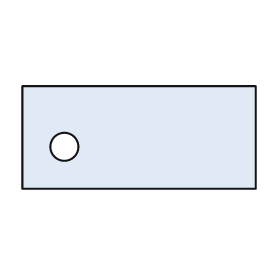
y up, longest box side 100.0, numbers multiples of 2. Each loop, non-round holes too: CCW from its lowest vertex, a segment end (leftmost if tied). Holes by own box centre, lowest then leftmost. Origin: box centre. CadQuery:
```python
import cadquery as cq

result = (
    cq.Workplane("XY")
    .moveTo(-50.0, -22.0)
    .lineTo(50.0, -22.0)
    .lineTo(50.0, 22.0)
    .lineTo(-50.0, 22.0)
    .close()
    .moveTo(-32.0, -4.0)
    .circle(6.0)
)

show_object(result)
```